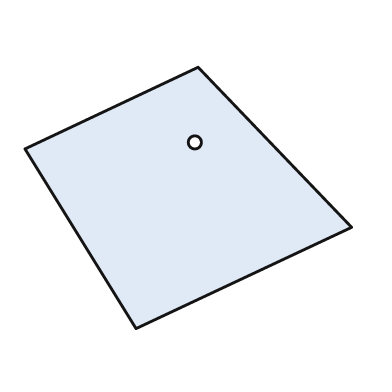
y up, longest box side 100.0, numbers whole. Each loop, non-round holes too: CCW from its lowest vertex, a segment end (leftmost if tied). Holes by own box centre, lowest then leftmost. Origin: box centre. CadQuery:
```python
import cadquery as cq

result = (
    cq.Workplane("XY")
    .moveTo(-16.0, -40.0)
    .lineTo(50.0, -9.0)
    .lineTo(3.0, 40.0)
    .lineTo(-50.0, 15.0)
    .close()
    .moveTo(2.0, 17.0)
    .circle(2.0)
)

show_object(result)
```